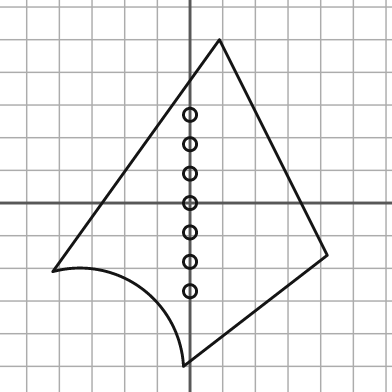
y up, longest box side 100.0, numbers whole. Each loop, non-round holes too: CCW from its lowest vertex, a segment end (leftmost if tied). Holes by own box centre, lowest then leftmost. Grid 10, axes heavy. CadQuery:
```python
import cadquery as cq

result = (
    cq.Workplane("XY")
    .moveTo(-2.0, -50.0)
    .lineTo(42.0, -16.0)
    .lineTo(9.0, 50.0)
    .lineTo(-42.0, -21.0)
    .threePointArc((-15.0, -26.0), (-2.0, -50.0))
    .close()
    .moveTo(0.0, -27.0)
    .circle(2.0)
    .moveTo(0.0, -18.0)
    .circle(2.0)
    .moveTo(0.0, -9.0)
    .circle(2.0)
    .moveTo(0.0, 0.0)
    .circle(2.0)
    .moveTo(0.0, 9.0)
    .circle(2.0)
    .moveTo(0.0, 18.0)
    .circle(2.0)
    .moveTo(0.0, 27.0)
    .circle(2.0)
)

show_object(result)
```